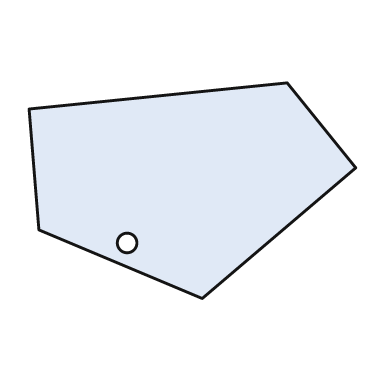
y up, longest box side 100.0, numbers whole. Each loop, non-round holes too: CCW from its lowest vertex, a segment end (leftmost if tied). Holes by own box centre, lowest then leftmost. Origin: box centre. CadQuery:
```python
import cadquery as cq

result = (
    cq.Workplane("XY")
    .moveTo(3.0, -33.0)
    .lineTo(50.0, 7.0)
    .lineTo(29.0, 33.0)
    .lineTo(-50.0, 25.0)
    .lineTo(-47.0, -12.0)
    .close()
    .moveTo(-20.0, -16.0)
    .circle(3.0)
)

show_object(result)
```